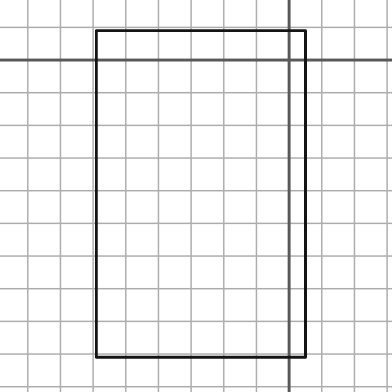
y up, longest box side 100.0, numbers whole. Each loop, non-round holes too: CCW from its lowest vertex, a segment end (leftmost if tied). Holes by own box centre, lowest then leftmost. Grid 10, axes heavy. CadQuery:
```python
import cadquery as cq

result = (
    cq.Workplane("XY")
    .moveTo(-59.0, -91.0)
    .lineTo(5.0, -91.0)
    .lineTo(5.0, 9.0)
    .lineTo(-59.0, 9.0)
    .close()
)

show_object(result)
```